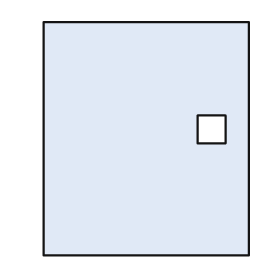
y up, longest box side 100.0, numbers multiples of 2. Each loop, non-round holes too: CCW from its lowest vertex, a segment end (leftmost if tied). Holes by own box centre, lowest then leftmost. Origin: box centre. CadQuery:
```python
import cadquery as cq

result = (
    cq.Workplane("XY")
    .moveTo(-44.0, -50.0)
    .lineTo(44.0, -50.0)
    .lineTo(44.0, 50.0)
    .lineTo(-44.0, 50.0)
    .close()
    .moveTo(22.0, -2.0)
    .lineTo(34.0, -2.0)
    .lineTo(34.0, 10.0)
    .lineTo(22.0, 10.0)
    .close()
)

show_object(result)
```